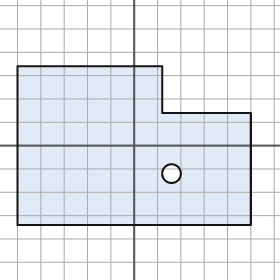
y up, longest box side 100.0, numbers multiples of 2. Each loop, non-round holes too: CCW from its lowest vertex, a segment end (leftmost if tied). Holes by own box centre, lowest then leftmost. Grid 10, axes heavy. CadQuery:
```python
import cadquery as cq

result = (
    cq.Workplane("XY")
    .moveTo(-50.0, -34.0)
    .lineTo(50.0, -34.0)
    .lineTo(50.0, 14.0)
    .lineTo(12.0, 14.0)
    .lineTo(12.0, 34.0)
    .lineTo(-50.0, 34.0)
    .close()
    .moveTo(16.0, -12.0)
    .circle(4.0)
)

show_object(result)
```